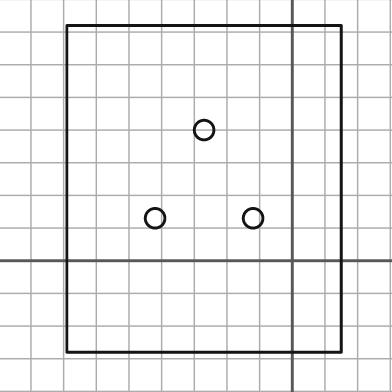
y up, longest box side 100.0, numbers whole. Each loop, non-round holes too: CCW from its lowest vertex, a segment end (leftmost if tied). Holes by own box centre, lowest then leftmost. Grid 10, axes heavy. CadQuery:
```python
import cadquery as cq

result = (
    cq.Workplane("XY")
    .moveTo(-69.0, -28.0)
    .lineTo(15.0, -28.0)
    .lineTo(15.0, 72.0)
    .lineTo(-69.0, 72.0)
    .close()
    .moveTo(-42.0, 13.0)
    .circle(3.0)
    .moveTo(-12.0, 13.0)
    .circle(3.0)
    .moveTo(-27.0, 40.0)
    .circle(3.0)
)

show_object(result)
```